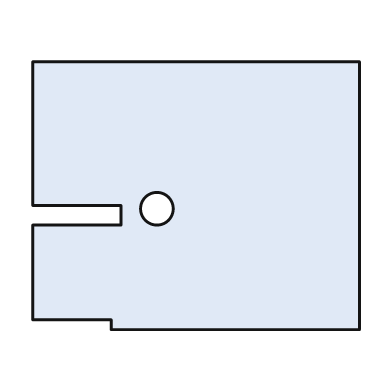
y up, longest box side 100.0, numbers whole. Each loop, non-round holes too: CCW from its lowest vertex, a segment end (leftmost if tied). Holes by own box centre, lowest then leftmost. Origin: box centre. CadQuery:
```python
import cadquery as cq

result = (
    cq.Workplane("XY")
    .moveTo(-26.0, -41.0)
    .lineTo(50.0, -41.0)
    .lineTo(50.0, 41.0)
    .lineTo(-50.0, 41.0)
    .lineTo(-50.0, -3.0)
    .lineTo(-23.0, -3.0)
    .lineTo(-23.0, -9.0)
    .lineTo(-50.0, -9.0)
    .lineTo(-50.0, -38.0)
    .lineTo(-26.0, -38.0)
    .close()
    .moveTo(-12.0, -4.0)
    .circle(5.0)
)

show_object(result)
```